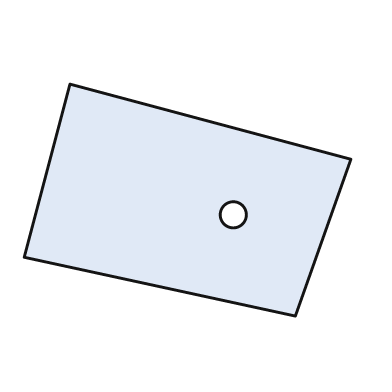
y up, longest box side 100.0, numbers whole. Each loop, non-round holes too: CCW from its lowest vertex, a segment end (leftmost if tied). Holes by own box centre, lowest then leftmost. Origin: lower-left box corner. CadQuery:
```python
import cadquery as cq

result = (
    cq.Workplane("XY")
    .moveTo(83.0, 0.0)
    .lineTo(100.0, 48.0)
    .lineTo(14.0, 71.0)
    .lineTo(0.0, 18.0)
    .close()
    .moveTo(64.0, 31.0)
    .circle(4.0)
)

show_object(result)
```